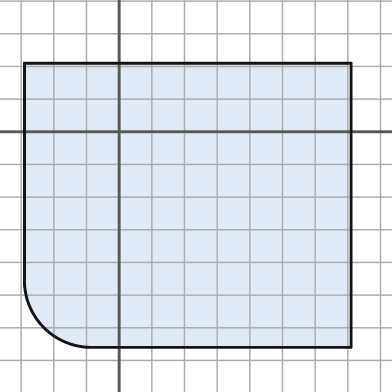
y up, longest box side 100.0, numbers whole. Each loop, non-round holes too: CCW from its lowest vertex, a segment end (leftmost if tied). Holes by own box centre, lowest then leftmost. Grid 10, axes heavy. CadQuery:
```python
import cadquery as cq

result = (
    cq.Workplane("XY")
    .moveTo(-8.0, -66.0)
    .lineTo(71.0, -66.0)
    .lineTo(71.0, 21.0)
    .lineTo(-29.0, 21.0)
    .lineTo(-29.0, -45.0)
    .threePointArc((-23.0, -60.0), (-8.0, -66.0))
    .close()
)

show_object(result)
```